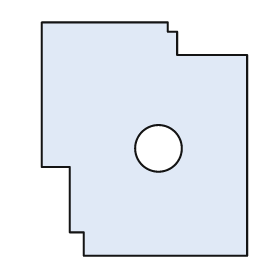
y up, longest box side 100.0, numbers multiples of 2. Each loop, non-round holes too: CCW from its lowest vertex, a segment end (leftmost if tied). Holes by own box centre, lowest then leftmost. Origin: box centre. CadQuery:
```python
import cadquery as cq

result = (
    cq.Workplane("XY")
    .moveTo(-26.0, -50.0)
    .lineTo(44.0, -50.0)
    .lineTo(44.0, 36.0)
    .lineTo(14.0, 36.0)
    .lineTo(14.0, 46.0)
    .lineTo(10.0, 46.0)
    .lineTo(10.0, 50.0)
    .lineTo(-44.0, 50.0)
    .lineTo(-44.0, -12.0)
    .lineTo(-32.0, -12.0)
    .lineTo(-32.0, -40.0)
    .lineTo(-26.0, -40.0)
    .close()
    .moveTo(6.0, -4.0)
    .circle(10.0)
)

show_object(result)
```